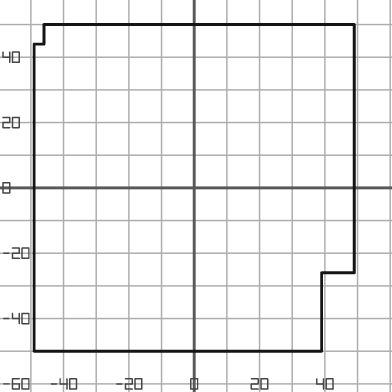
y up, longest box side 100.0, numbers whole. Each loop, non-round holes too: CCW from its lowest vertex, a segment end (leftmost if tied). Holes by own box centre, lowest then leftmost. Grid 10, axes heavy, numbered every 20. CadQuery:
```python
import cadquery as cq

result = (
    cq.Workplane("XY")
    .moveTo(-49.0, -50.0)
    .lineTo(39.0, -50.0)
    .lineTo(39.0, -26.0)
    .lineTo(49.0, -26.0)
    .lineTo(49.0, 50.0)
    .lineTo(-46.0, 50.0)
    .lineTo(-46.0, 44.0)
    .lineTo(-49.0, 44.0)
    .close()
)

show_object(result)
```